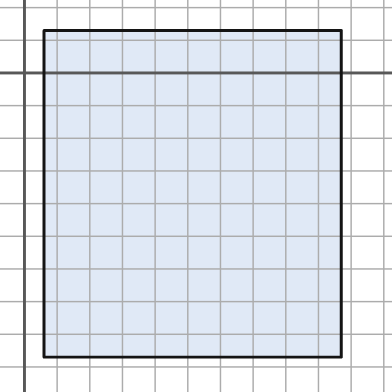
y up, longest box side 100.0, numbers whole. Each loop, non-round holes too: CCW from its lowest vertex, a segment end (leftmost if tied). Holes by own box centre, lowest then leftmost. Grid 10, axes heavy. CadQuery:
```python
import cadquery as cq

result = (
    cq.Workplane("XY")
    .moveTo(6.0, -87.0)
    .lineTo(97.0, -87.0)
    .lineTo(97.0, 13.0)
    .lineTo(6.0, 13.0)
    .close()
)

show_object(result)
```